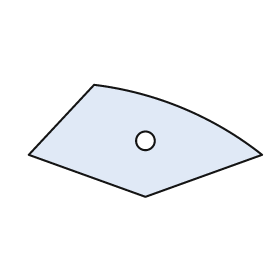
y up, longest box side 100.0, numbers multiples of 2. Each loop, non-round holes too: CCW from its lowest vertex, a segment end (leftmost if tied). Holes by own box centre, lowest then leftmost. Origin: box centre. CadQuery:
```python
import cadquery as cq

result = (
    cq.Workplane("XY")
    .moveTo(0.0, -24.0)
    .lineTo(50.0, -6.0)
    .threePointArc((16.0, 14.0), (-22.0, 24.0))
    .lineTo(-50.0, -6.0)
    .close()
    .moveTo(0.0, 0.0)
    .circle(4.0)
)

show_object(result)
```